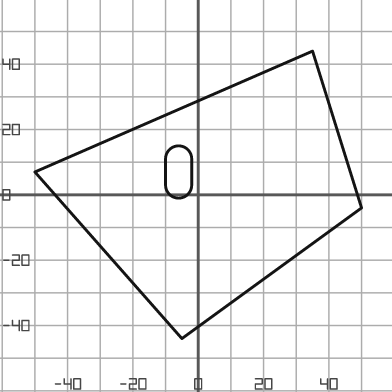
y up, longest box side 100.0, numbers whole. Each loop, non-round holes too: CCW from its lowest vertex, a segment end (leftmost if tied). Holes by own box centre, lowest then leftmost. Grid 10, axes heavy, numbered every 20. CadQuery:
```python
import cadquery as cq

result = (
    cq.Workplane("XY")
    .moveTo(-5.0, -44.0)
    .lineTo(50.0, -4.0)
    .lineTo(35.0, 44.0)
    .lineTo(-50.0, 7.0)
    .close()
    .moveTo(-10.0, 3.0)
    .threePointArc((-6.0, -1.0), (-2.0, 3.0))
    .lineTo(-2.0, 11.0)
    .threePointArc((-6.0, 15.0), (-10.0, 11.0))
    .close()
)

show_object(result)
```